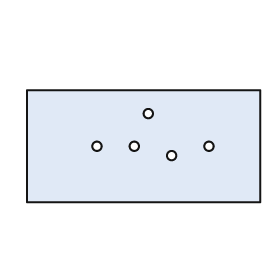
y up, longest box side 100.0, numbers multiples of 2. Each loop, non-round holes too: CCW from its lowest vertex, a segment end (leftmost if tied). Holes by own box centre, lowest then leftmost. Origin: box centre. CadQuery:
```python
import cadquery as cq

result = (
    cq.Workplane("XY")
    .moveTo(-50.0, -24.0)
    .lineTo(50.0, -24.0)
    .lineTo(50.0, 24.0)
    .lineTo(-50.0, 24.0)
    .close()
    .moveTo(12.0, -4.0)
    .circle(2.0)
    .moveTo(-20.0, 0.0)
    .circle(2.0)
    .moveTo(-4.0, 0.0)
    .circle(2.0)
    .moveTo(28.0, 0.0)
    .circle(2.0)
    .moveTo(2.0, 14.0)
    .circle(2.0)
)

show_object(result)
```